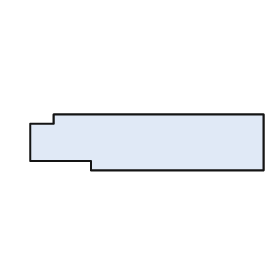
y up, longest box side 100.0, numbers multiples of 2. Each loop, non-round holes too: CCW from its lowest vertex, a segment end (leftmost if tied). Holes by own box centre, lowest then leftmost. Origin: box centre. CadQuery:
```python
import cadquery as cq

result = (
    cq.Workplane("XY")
    .moveTo(-24.0, -12.0)
    .lineTo(50.0, -12.0)
    .lineTo(50.0, 12.0)
    .lineTo(-40.0, 12.0)
    .lineTo(-40.0, 8.0)
    .lineTo(-50.0, 8.0)
    .lineTo(-50.0, -8.0)
    .lineTo(-24.0, -8.0)
    .close()
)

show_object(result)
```